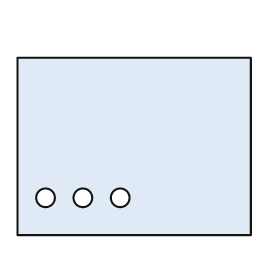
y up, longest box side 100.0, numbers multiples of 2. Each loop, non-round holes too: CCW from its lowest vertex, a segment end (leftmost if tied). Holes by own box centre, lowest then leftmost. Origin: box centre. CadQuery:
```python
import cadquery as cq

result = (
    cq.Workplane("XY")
    .moveTo(-50.0, -38.0)
    .lineTo(50.0, -38.0)
    .lineTo(50.0, 38.0)
    .lineTo(-50.0, 38.0)
    .close()
    .moveTo(-38.0, -22.0)
    .circle(4.0)
    .moveTo(-22.0, -22.0)
    .circle(4.0)
    .moveTo(-6.0, -22.0)
    .circle(4.0)
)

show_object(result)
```